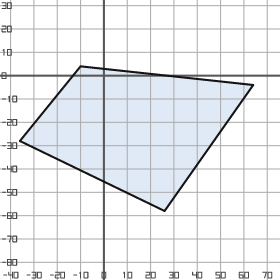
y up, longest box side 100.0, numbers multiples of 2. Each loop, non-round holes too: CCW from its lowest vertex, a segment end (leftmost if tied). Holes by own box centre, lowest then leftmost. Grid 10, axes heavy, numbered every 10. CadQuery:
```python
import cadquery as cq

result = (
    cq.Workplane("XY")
    .moveTo(26.0, -58.0)
    .lineTo(64.0, -4.0)
    .lineTo(-10.0, 4.0)
    .lineTo(-36.0, -28.0)
    .close()
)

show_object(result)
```